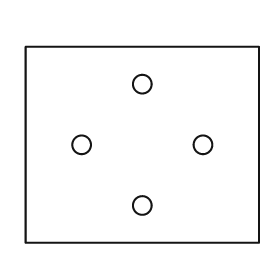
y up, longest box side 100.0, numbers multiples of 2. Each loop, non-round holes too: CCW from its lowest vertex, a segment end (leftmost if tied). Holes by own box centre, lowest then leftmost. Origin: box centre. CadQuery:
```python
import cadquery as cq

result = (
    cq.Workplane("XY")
    .moveTo(-50.0, -42.0)
    .lineTo(50.0, -42.0)
    .lineTo(50.0, 42.0)
    .lineTo(-50.0, 42.0)
    .close()
    .moveTo(0.0, -26.0)
    .circle(4.0)
    .moveTo(-26.0, 0.0)
    .circle(4.0)
    .moveTo(26.0, 0.0)
    .circle(4.0)
    .moveTo(0.0, 26.0)
    .circle(4.0)
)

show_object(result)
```